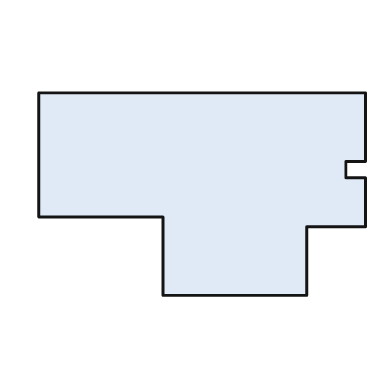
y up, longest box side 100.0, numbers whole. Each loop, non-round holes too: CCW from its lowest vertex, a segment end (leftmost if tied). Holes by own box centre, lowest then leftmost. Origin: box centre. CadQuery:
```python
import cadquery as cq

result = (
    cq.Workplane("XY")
    .moveTo(-12.0, -31.0)
    .lineTo(32.0, -31.0)
    .lineTo(32.0, -10.0)
    .lineTo(50.0, -10.0)
    .lineTo(50.0, 5.0)
    .lineTo(44.0, 5.0)
    .lineTo(44.0, 10.0)
    .lineTo(50.0, 10.0)
    .lineTo(50.0, 31.0)
    .lineTo(-50.0, 31.0)
    .lineTo(-50.0, -7.0)
    .lineTo(-12.0, -7.0)
    .close()
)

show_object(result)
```